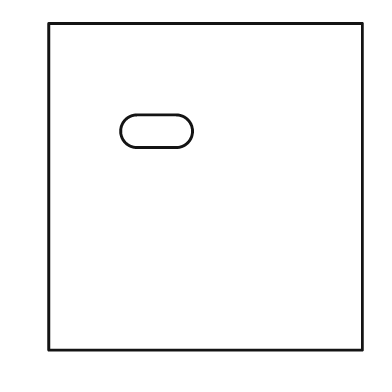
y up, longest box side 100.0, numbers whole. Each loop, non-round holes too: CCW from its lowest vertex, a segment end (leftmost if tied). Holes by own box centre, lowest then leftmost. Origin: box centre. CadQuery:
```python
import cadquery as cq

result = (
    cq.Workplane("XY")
    .moveTo(-48.0, -50.0)
    .lineTo(48.0, -50.0)
    .lineTo(48.0, 50.0)
    .lineTo(-48.0, 50.0)
    .close()
    .moveTo(-21.0, 12.0)
    .lineTo(-9.0, 12.0)
    .threePointArc((-4.0, 17.0), (-9.0, 22.0))
    .lineTo(-21.0, 22.0)
    .threePointArc((-26.0, 17.0), (-21.0, 12.0))
    .close()
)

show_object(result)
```